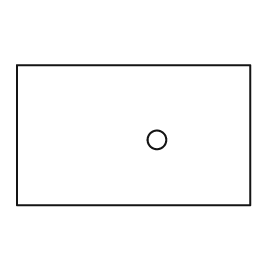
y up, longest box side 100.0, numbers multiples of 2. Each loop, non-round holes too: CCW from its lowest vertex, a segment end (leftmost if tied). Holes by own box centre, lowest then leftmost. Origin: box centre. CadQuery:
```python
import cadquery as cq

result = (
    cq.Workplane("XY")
    .moveTo(-50.0, -30.0)
    .lineTo(50.0, -30.0)
    .lineTo(50.0, 30.0)
    .lineTo(-50.0, 30.0)
    .close()
    .moveTo(10.0, -2.0)
    .circle(4.0)
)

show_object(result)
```